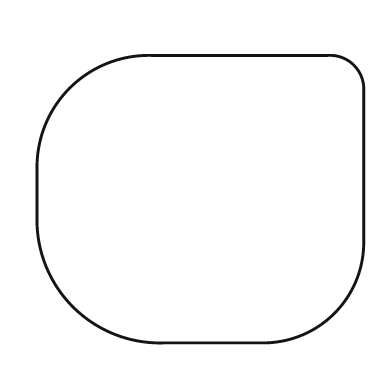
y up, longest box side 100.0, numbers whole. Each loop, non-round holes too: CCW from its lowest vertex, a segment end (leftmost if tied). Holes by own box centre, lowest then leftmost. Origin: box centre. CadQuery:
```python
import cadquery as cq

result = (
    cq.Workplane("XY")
    .moveTo(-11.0, -44.0)
    .lineTo(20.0, -44.0)
    .threePointArc((41.0, -35.0), (50.0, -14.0))
    .lineTo(50.0, 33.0)
    .threePointArc((47.0, 41.0), (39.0, 44.0))
    .lineTo(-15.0, 44.0)
    .threePointArc((-40.0, 34.0), (-50.0, 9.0))
    .lineTo(-50.0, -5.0)
    .threePointArc((-39.0, -33.0), (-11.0, -44.0))
    .close()
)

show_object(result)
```